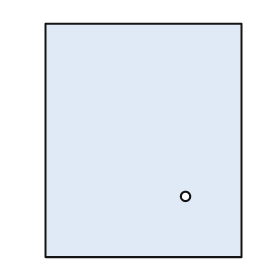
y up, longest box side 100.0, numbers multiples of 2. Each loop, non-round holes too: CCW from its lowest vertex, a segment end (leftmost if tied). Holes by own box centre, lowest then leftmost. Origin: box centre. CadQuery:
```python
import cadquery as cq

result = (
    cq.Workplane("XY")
    .moveTo(-42.0, -50.0)
    .lineTo(42.0, -50.0)
    .lineTo(42.0, 50.0)
    .lineTo(-42.0, 50.0)
    .close()
    .moveTo(18.0, -24.0)
    .circle(2.0)
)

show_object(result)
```